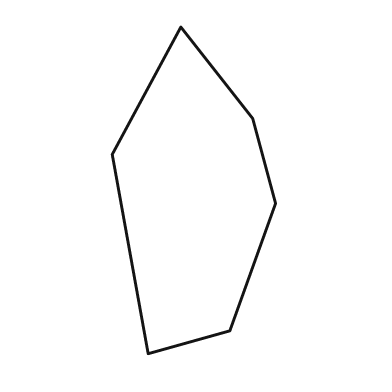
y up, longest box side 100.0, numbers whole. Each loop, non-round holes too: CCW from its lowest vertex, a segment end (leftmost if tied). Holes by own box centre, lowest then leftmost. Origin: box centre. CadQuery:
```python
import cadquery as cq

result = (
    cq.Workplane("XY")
    .moveTo(-14.0, -50.0)
    .lineTo(11.0, -43.0)
    .lineTo(25.0, -4.0)
    .lineTo(18.0, 22.0)
    .lineTo(-4.0, 50.0)
    .lineTo(-25.0, 11.0)
    .close()
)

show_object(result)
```